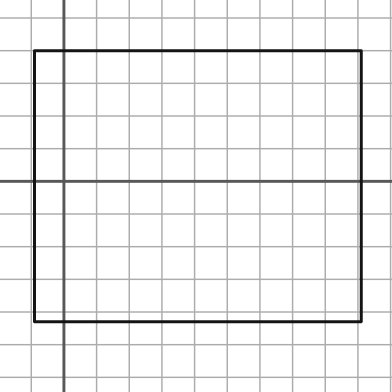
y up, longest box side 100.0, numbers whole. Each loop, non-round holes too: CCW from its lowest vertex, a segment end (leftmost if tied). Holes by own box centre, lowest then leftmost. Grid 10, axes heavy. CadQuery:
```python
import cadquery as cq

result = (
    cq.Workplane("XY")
    .moveTo(-9.0, -43.0)
    .lineTo(91.0, -43.0)
    .lineTo(91.0, 40.0)
    .lineTo(-9.0, 40.0)
    .close()
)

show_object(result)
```